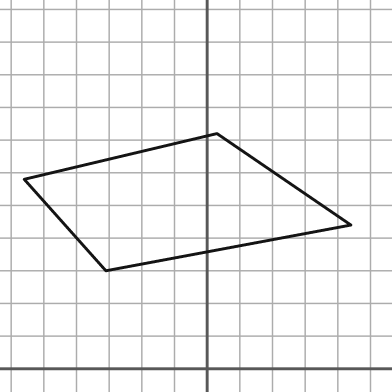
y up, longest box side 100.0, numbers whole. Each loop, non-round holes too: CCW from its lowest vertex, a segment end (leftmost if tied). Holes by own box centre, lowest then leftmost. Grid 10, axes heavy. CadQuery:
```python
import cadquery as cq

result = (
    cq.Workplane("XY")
    .moveTo(-31.0, 30.0)
    .lineTo(44.0, 44.0)
    .lineTo(3.0, 72.0)
    .lineTo(-56.0, 58.0)
    .close()
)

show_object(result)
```